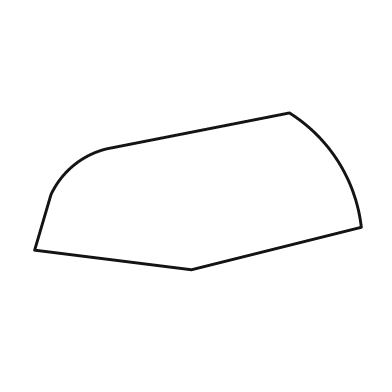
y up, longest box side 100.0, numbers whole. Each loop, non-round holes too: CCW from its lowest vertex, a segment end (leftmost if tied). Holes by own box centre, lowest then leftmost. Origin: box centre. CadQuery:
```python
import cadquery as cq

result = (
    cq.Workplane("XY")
    .moveTo(-2.0, -24.0)
    .lineTo(50.0, -11.0)
    .threePointArc((43.0, 9.0), (28.0, 24.0))
    .lineTo(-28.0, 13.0)
    .threePointArc((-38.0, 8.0), (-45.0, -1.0))
    .lineTo(-50.0, -18.0)
    .close()
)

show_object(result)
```